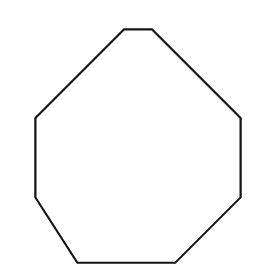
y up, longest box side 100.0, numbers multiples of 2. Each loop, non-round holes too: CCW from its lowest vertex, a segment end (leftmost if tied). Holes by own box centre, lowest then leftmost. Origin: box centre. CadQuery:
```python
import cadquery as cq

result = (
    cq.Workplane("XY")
    .moveTo(-26.0, -50.0)
    .lineTo(16.0, -50.0)
    .lineTo(44.0, -22.0)
    .lineTo(44.0, 12.0)
    .lineTo(6.0, 50.0)
    .lineTo(-6.0, 50.0)
    .lineTo(-44.0, 12.0)
    .lineTo(-44.0, -22.0)
    .close()
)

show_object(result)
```